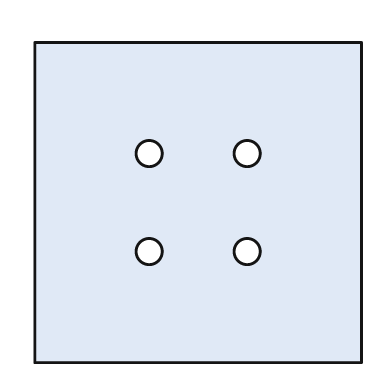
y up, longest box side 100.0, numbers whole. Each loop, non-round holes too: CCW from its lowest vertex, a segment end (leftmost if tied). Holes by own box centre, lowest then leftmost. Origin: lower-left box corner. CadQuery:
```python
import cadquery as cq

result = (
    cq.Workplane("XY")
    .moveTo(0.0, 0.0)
    .lineTo(100.0, 0.0)
    .lineTo(100.0, 98.0)
    .lineTo(0.0, 98.0)
    .close()
    .moveTo(35.0, 34.0)
    .circle(4.0)
    .moveTo(65.0, 34.0)
    .circle(4.0)
    .moveTo(35.0, 64.0)
    .circle(4.0)
    .moveTo(65.0, 64.0)
    .circle(4.0)
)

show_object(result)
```